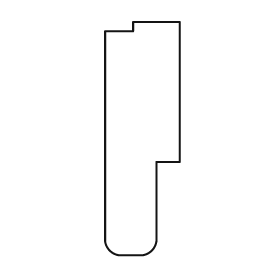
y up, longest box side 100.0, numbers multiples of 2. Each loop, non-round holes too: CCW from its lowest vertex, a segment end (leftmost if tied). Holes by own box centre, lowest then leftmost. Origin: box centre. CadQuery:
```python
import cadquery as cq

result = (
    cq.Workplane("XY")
    .moveTo(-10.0, -50.0)
    .lineTo(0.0, -50.0)
    .threePointArc((4.0, -48.0), (6.0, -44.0))
    .lineTo(6.0, -10.0)
    .lineTo(16.0, -10.0)
    .lineTo(16.0, 50.0)
    .lineTo(-4.0, 50.0)
    .lineTo(-4.0, 46.0)
    .lineTo(-16.0, 46.0)
    .lineTo(-16.0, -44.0)
    .threePointArc((-14.0, -48.0), (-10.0, -50.0))
    .close()
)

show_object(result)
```